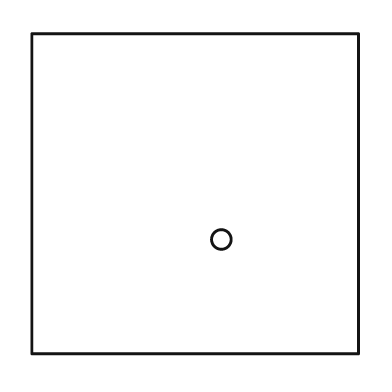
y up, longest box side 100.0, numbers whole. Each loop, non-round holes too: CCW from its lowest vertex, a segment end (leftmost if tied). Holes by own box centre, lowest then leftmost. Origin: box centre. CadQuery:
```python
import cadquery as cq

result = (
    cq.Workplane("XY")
    .moveTo(-50.0, -49.0)
    .lineTo(50.0, -49.0)
    .lineTo(50.0, 49.0)
    .lineTo(-50.0, 49.0)
    .close()
    .moveTo(8.0, -14.0)
    .circle(3.0)
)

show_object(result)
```